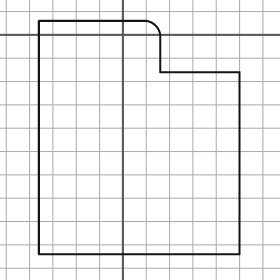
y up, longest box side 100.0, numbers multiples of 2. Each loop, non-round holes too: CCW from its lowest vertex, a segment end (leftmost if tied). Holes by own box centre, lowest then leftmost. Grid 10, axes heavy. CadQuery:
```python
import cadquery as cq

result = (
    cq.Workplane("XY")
    .moveTo(-36.0, -94.0)
    .lineTo(50.0, -94.0)
    .lineTo(50.0, -16.0)
    .lineTo(16.0, -16.0)
    .lineTo(16.0, 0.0)
    .threePointArc((14.0, 4.0), (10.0, 6.0))
    .lineTo(-36.0, 6.0)
    .close()
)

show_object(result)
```